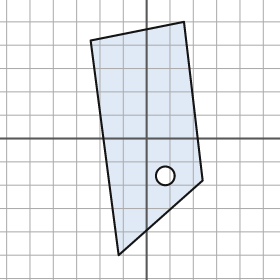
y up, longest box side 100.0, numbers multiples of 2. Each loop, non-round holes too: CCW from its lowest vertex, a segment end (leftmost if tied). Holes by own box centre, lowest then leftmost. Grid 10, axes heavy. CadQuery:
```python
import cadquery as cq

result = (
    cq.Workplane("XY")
    .moveTo(-12.0, -50.0)
    .lineTo(24.0, -18.0)
    .lineTo(16.0, 50.0)
    .lineTo(-24.0, 42.0)
    .close()
    .moveTo(8.0, -16.0)
    .circle(4.0)
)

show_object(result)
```